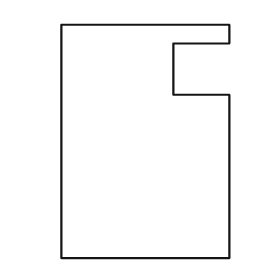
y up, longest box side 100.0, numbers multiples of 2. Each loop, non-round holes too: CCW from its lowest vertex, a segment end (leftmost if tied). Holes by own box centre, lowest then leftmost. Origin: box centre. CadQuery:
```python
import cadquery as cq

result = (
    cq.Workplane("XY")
    .moveTo(-36.0, -50.0)
    .lineTo(36.0, -50.0)
    .lineTo(36.0, 20.0)
    .lineTo(12.0, 20.0)
    .lineTo(12.0, 42.0)
    .lineTo(36.0, 42.0)
    .lineTo(36.0, 50.0)
    .lineTo(-36.0, 50.0)
    .close()
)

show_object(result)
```